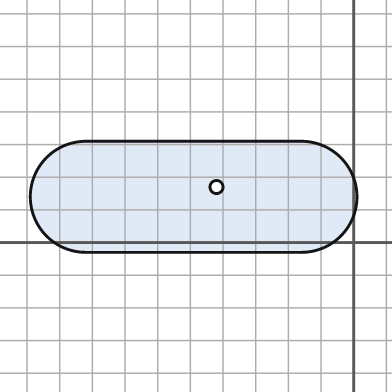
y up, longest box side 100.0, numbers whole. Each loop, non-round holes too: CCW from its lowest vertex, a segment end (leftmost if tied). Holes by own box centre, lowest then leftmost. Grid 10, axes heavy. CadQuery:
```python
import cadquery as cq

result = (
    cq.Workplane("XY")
    .moveTo(-82.0, -3.0)
    .lineTo(-16.0, -3.0)
    .threePointArc((1.0, 14.0), (-16.0, 31.0))
    .lineTo(-82.0, 31.0)
    .threePointArc((-99.0, 14.0), (-82.0, -3.0))
    .close()
    .moveTo(-42.0, 17.0)
    .circle(2.0)
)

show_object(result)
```